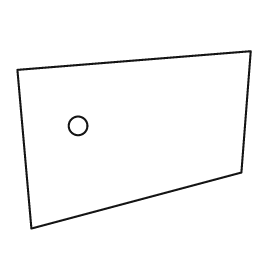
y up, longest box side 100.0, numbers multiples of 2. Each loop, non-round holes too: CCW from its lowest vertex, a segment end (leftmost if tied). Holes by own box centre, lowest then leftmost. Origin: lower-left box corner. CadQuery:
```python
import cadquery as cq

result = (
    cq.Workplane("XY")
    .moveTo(6.0, 0.0)
    .lineTo(96.0, 24.0)
    .lineTo(100.0, 76.0)
    .lineTo(0.0, 68.0)
    .close()
    .moveTo(26.0, 44.0)
    .circle(4.0)
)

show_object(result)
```